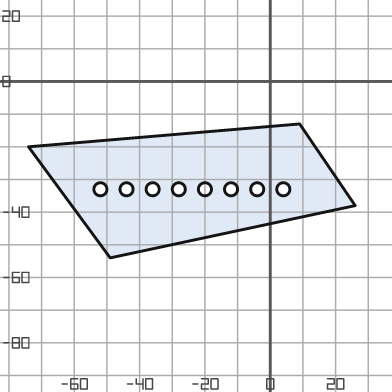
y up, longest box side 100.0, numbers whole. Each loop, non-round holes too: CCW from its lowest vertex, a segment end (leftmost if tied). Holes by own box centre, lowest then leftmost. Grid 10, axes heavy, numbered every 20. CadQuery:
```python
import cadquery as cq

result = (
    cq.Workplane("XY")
    .moveTo(-49.0, -54.0)
    .lineTo(26.0, -38.0)
    .lineTo(9.0, -13.0)
    .lineTo(-74.0, -20.0)
    .close()
    .moveTo(-52.0, -33.0)
    .circle(2.0)
    .moveTo(-44.0, -33.0)
    .circle(2.0)
    .moveTo(-36.0, -33.0)
    .circle(2.0)
    .moveTo(-28.0, -33.0)
    .circle(2.0)
    .moveTo(-20.0, -33.0)
    .circle(2.0)
    .moveTo(-12.0, -33.0)
    .circle(2.0)
    .moveTo(-4.0, -33.0)
    .circle(2.0)
    .moveTo(4.0, -33.0)
    .circle(2.0)
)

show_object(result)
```